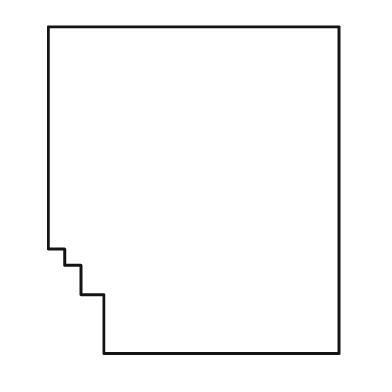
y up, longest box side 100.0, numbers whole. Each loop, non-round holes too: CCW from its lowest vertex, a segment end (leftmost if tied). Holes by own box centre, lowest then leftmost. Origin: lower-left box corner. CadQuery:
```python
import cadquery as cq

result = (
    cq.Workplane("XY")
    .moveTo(17.0, 0.0)
    .lineTo(89.0, 0.0)
    .lineTo(89.0, 100.0)
    .lineTo(0.0, 100.0)
    .lineTo(0.0, 32.0)
    .lineTo(5.0, 32.0)
    .lineTo(5.0, 27.0)
    .lineTo(10.0, 27.0)
    .lineTo(10.0, 18.0)
    .lineTo(17.0, 18.0)
    .close()
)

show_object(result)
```